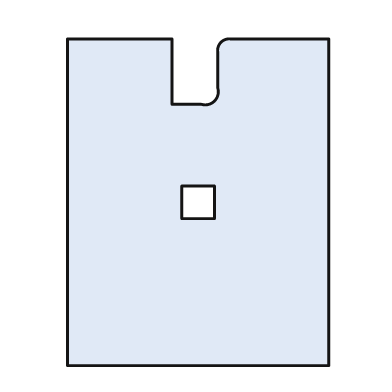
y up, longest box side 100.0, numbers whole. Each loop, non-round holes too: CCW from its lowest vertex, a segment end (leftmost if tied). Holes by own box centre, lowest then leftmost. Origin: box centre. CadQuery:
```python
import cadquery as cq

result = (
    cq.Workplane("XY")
    .moveTo(-40.0, -50.0)
    .lineTo(40.0, -50.0)
    .lineTo(40.0, 50.0)
    .lineTo(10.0, 50.0)
    .threePointArc((7.0, 49.0), (6.0, 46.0))
    .lineTo(6.0, 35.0)
    .threePointArc((5.0, 31.0), (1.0, 30.0))
    .lineTo(-8.0, 30.0)
    .lineTo(-8.0, 50.0)
    .lineTo(-40.0, 50.0)
    .close()
    .moveTo(-5.0, -5.0)
    .lineTo(5.0, -5.0)
    .lineTo(5.0, 5.0)
    .lineTo(-5.0, 5.0)
    .close()
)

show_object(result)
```